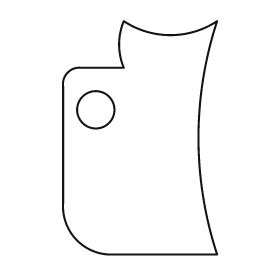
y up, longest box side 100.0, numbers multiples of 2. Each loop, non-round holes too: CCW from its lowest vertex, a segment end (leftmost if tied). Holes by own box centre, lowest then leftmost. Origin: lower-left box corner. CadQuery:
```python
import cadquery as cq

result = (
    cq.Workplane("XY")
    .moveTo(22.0, 0.0)
    .lineTo(66.0, 0.0)
    .threePointArc((58.0, 50.0), (66.0, 100.0))
    .threePointArc((46.0, 94.0), (26.0, 100.0))
    .threePointArc((24.0, 90.0), (26.0, 80.0))
    .lineTo(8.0, 80.0)
    .threePointArc((2.0, 78.0), (0.0, 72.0))
    .lineTo(0.0, 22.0)
    .threePointArc((6.0, 6.0), (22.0, 0.0))
    .close()
    .moveTo(14.0, 62.0)
    .circle(8.0)
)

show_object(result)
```